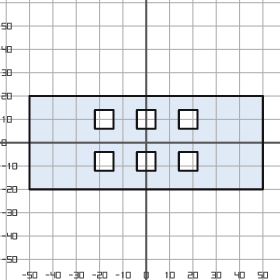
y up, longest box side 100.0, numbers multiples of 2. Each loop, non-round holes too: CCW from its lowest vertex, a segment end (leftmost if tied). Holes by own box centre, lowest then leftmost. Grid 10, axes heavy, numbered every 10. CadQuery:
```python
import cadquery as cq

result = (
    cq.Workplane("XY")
    .moveTo(-50.0, -20.0)
    .lineTo(50.0, -20.0)
    .lineTo(50.0, 20.0)
    .lineTo(-50.0, 20.0)
    .close()
    .moveTo(-22.0, -12.0)
    .lineTo(-14.0, -12.0)
    .lineTo(-14.0, -4.0)
    .lineTo(-22.0, -4.0)
    .close()
    .moveTo(-4.0, -12.0)
    .lineTo(4.0, -12.0)
    .lineTo(4.0, -4.0)
    .lineTo(-4.0, -4.0)
    .close()
    .moveTo(14.0, -12.0)
    .lineTo(22.0, -12.0)
    .lineTo(22.0, -4.0)
    .lineTo(14.0, -4.0)
    .close()
    .moveTo(-22.0, 6.0)
    .lineTo(-14.0, 6.0)
    .lineTo(-14.0, 14.0)
    .lineTo(-22.0, 14.0)
    .close()
    .moveTo(-4.0, 6.0)
    .lineTo(4.0, 6.0)
    .lineTo(4.0, 14.0)
    .lineTo(-4.0, 14.0)
    .close()
    .moveTo(14.0, 6.0)
    .lineTo(22.0, 6.0)
    .lineTo(22.0, 14.0)
    .lineTo(14.0, 14.0)
    .close()
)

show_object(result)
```